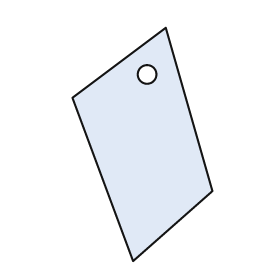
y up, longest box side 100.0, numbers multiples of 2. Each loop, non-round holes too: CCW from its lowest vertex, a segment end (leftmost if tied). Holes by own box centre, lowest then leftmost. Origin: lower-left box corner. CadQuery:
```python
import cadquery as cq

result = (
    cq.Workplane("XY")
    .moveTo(26.0, 0.0)
    .lineTo(60.0, 30.0)
    .lineTo(40.0, 100.0)
    .lineTo(0.0, 70.0)
    .close()
    .moveTo(32.0, 80.0)
    .circle(4.0)
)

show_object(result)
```